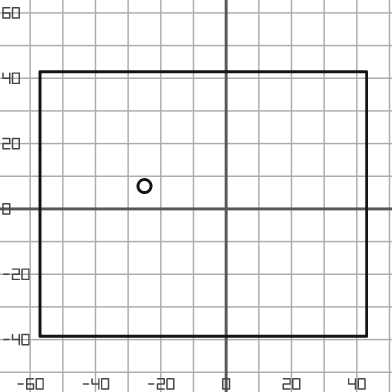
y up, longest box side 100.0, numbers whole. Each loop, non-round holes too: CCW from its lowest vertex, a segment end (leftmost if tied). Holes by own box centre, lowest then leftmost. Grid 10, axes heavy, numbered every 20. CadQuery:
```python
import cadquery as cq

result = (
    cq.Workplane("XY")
    .moveTo(-57.0, -39.0)
    .lineTo(43.0, -39.0)
    .lineTo(43.0, 42.0)
    .lineTo(-57.0, 42.0)
    .close()
    .moveTo(-25.0, 7.0)
    .circle(2.0)
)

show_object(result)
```